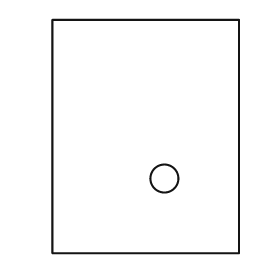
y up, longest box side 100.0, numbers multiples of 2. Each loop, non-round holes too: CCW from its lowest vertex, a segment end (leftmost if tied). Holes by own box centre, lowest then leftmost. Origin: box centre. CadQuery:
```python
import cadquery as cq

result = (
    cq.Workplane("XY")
    .moveTo(-40.0, -50.0)
    .lineTo(40.0, -50.0)
    .lineTo(40.0, 50.0)
    .lineTo(-40.0, 50.0)
    .close()
    .moveTo(8.0, -18.0)
    .circle(6.0)
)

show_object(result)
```